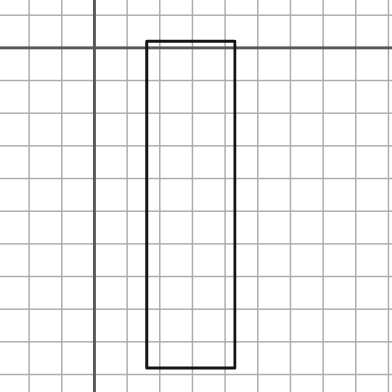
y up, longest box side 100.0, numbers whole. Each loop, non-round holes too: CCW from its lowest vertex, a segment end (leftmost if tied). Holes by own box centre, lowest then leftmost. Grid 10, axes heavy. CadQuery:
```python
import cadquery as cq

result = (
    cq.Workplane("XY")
    .moveTo(16.0, -98.0)
    .lineTo(43.0, -98.0)
    .lineTo(43.0, 2.0)
    .lineTo(16.0, 2.0)
    .close()
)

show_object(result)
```